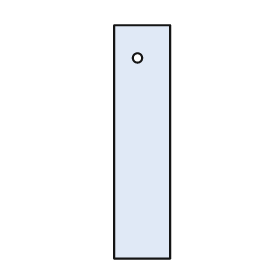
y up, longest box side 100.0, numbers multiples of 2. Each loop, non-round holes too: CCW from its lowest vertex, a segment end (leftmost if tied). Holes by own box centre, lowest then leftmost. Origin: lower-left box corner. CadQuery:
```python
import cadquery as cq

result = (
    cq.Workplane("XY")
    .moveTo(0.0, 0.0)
    .lineTo(24.0, 0.0)
    .lineTo(24.0, 100.0)
    .lineTo(0.0, 100.0)
    .close()
    .moveTo(10.0, 86.0)
    .circle(2.0)
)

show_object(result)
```